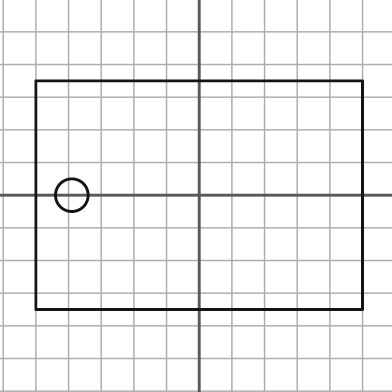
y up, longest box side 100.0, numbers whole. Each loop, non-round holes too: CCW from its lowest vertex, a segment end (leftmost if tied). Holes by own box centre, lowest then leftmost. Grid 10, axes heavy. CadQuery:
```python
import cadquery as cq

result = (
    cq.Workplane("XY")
    .moveTo(-50.0, -35.0)
    .lineTo(50.0, -35.0)
    .lineTo(50.0, 35.0)
    .lineTo(-50.0, 35.0)
    .close()
    .moveTo(-39.0, 0.0)
    .circle(5.0)
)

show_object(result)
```